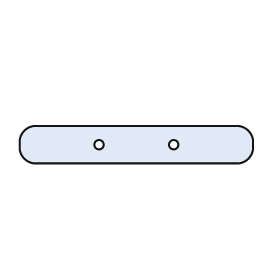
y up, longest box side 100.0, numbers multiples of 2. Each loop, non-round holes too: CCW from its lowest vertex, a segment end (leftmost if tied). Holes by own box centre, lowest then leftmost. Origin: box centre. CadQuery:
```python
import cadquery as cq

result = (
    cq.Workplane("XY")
    .moveTo(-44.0, -8.0)
    .lineTo(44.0, -8.0)
    .threePointArc((48.0, -6.0), (50.0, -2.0))
    .lineTo(50.0, 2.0)
    .threePointArc((48.0, 6.0), (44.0, 8.0))
    .lineTo(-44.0, 8.0)
    .threePointArc((-48.0, 6.0), (-50.0, 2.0))
    .lineTo(-50.0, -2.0)
    .threePointArc((-48.0, -6.0), (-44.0, -8.0))
    .close()
    .moveTo(-16.0, 0.0)
    .circle(2.0)
    .moveTo(16.0, 0.0)
    .circle(2.0)
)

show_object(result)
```